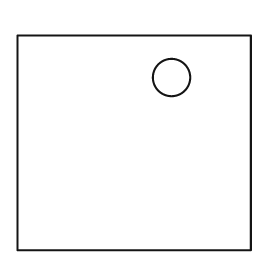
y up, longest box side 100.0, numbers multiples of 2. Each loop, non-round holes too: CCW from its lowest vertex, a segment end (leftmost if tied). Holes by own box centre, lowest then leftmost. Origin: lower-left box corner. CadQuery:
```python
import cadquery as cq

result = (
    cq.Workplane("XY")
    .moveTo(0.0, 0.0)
    .lineTo(100.0, 0.0)
    .lineTo(100.0, 92.0)
    .lineTo(0.0, 92.0)
    .close()
    .moveTo(66.0, 74.0)
    .circle(8.0)
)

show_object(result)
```